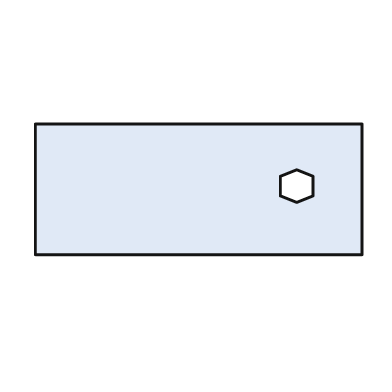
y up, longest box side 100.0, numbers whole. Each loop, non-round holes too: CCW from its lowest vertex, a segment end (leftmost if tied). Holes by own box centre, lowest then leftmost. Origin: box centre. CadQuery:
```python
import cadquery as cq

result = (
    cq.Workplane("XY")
    .moveTo(-50.0, -20.0)
    .lineTo(50.0, -20.0)
    .lineTo(50.0, 20.0)
    .lineTo(-50.0, 20.0)
    .close()
    .moveTo(30.0, -4.0)
    .lineTo(35.0, -2.0)
    .lineTo(35.0, 4.0)
    .lineTo(30.0, 6.0)
    .lineTo(25.0, 4.0)
    .lineTo(25.0, -2.0)
    .close()
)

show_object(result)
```